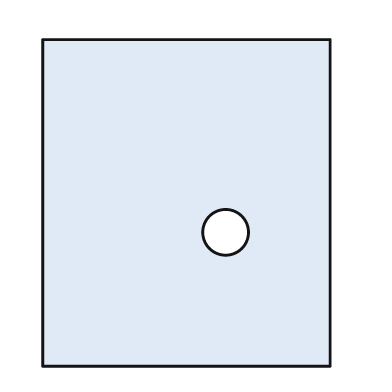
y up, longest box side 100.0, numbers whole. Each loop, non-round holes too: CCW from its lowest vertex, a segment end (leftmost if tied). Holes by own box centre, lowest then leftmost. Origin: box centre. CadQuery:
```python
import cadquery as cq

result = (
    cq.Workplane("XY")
    .moveTo(-44.0, -50.0)
    .lineTo(44.0, -50.0)
    .lineTo(44.0, 50.0)
    .lineTo(-44.0, 50.0)
    .close()
    .moveTo(12.0, -9.0)
    .circle(7.0)
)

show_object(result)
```